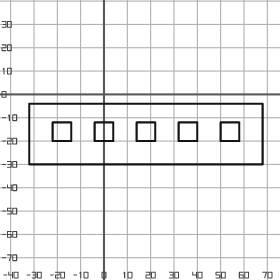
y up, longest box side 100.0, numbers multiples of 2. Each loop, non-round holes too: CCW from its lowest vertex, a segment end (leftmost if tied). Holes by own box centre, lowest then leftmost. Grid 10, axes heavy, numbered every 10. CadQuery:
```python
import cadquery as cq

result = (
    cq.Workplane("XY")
    .moveTo(-32.0, -30.0)
    .lineTo(68.0, -30.0)
    .lineTo(68.0, -4.0)
    .lineTo(-32.0, -4.0)
    .close()
    .moveTo(-22.0, -20.0)
    .lineTo(-14.0, -20.0)
    .lineTo(-14.0, -12.0)
    .lineTo(-22.0, -12.0)
    .close()
    .moveTo(-4.0, -20.0)
    .lineTo(4.0, -20.0)
    .lineTo(4.0, -12.0)
    .lineTo(-4.0, -12.0)
    .close()
    .moveTo(14.0, -20.0)
    .lineTo(22.0, -20.0)
    .lineTo(22.0, -12.0)
    .lineTo(14.0, -12.0)
    .close()
    .moveTo(32.0, -20.0)
    .lineTo(40.0, -20.0)
    .lineTo(40.0, -12.0)
    .lineTo(32.0, -12.0)
    .close()
    .moveTo(50.0, -20.0)
    .lineTo(58.0, -20.0)
    .lineTo(58.0, -12.0)
    .lineTo(50.0, -12.0)
    .close()
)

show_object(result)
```